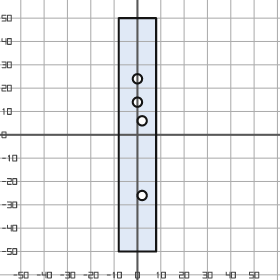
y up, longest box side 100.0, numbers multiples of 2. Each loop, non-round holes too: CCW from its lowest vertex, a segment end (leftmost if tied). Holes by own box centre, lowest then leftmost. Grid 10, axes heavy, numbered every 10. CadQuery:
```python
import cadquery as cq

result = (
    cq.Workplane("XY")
    .moveTo(-8.0, -50.0)
    .lineTo(8.0, -50.0)
    .lineTo(8.0, 50.0)
    .lineTo(-8.0, 50.0)
    .close()
    .moveTo(2.0, -26.0)
    .circle(2.0)
    .moveTo(2.0, 6.0)
    .circle(2.0)
    .moveTo(0.0, 14.0)
    .circle(2.0)
    .moveTo(0.0, 24.0)
    .circle(2.0)
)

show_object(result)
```